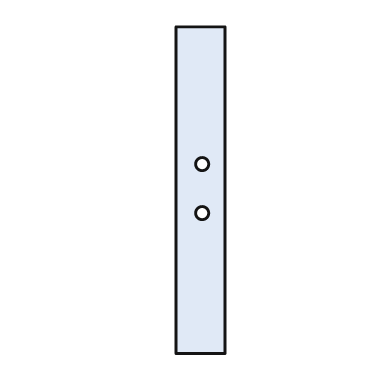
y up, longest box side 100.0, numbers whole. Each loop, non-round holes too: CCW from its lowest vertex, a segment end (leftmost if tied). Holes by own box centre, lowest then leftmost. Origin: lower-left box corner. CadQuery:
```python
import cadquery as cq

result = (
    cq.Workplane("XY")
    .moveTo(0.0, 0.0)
    .lineTo(15.0, 0.0)
    .lineTo(15.0, 100.0)
    .lineTo(0.0, 100.0)
    .close()
    .moveTo(8.0, 43.0)
    .circle(2.0)
    .moveTo(8.0, 58.0)
    .circle(2.0)
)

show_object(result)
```